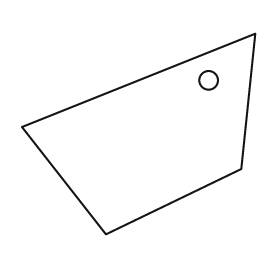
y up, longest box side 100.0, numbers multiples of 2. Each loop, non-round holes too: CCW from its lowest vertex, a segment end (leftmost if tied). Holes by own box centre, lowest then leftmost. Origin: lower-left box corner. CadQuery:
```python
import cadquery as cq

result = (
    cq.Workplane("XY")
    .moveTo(36.0, 0.0)
    .lineTo(94.0, 28.0)
    .lineTo(100.0, 86.0)
    .lineTo(0.0, 46.0)
    .close()
    .moveTo(80.0, 66.0)
    .circle(4.0)
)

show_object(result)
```